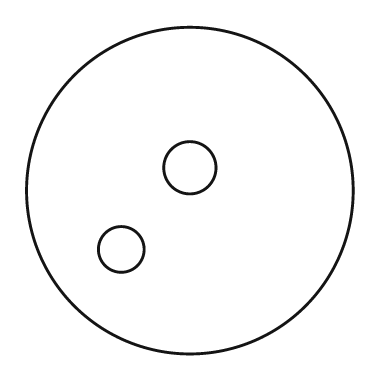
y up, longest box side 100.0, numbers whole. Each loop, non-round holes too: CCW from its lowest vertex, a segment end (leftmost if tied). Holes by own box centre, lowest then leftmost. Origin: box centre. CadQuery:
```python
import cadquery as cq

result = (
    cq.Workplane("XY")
    .moveTo(0.0, 0.0)
    .circle(50.0)
    .moveTo(-21.0, -18.0)
    .circle(7.0)
    .moveTo(0.0, 7.0)
    .circle(8.0)
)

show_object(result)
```